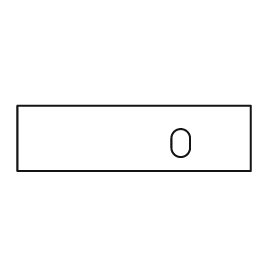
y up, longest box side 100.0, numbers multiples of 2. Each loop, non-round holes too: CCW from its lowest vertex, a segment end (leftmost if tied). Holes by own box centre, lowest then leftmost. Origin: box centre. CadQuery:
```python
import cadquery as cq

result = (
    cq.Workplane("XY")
    .moveTo(-50.0, -14.0)
    .lineTo(50.0, -14.0)
    .lineTo(50.0, 14.0)
    .lineTo(-50.0, 14.0)
    .close()
    .moveTo(16.0, -4.0)
    .threePointArc((20.0, -8.0), (24.0, -4.0))
    .lineTo(24.0, 0.0)
    .threePointArc((20.0, 4.0), (16.0, 0.0))
    .close()
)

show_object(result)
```